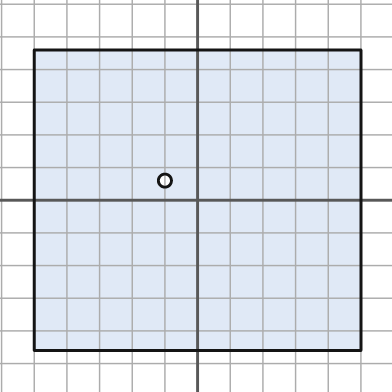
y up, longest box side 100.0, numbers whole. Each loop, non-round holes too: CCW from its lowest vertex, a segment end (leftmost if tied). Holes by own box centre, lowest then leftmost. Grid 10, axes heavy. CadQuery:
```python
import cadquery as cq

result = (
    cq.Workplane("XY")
    .moveTo(-50.0, -46.0)
    .lineTo(50.0, -46.0)
    .lineTo(50.0, 46.0)
    .lineTo(-50.0, 46.0)
    .close()
    .moveTo(-10.0, 6.0)
    .circle(2.0)
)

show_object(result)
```